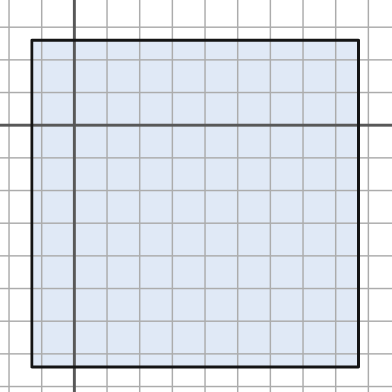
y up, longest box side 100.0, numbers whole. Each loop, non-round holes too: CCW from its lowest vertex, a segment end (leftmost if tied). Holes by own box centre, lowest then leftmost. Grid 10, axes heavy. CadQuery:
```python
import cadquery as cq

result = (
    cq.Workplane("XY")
    .moveTo(-13.0, -74.0)
    .lineTo(87.0, -74.0)
    .lineTo(87.0, 26.0)
    .lineTo(-13.0, 26.0)
    .close()
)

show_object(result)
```